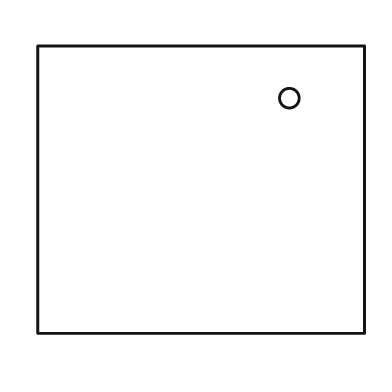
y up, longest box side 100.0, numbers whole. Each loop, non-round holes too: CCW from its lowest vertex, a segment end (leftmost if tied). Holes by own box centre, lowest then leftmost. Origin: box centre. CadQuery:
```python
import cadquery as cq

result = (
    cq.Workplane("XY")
    .moveTo(-50.0, -44.0)
    .lineTo(50.0, -44.0)
    .lineTo(50.0, 44.0)
    .lineTo(-50.0, 44.0)
    .close()
    .moveTo(27.0, 28.0)
    .circle(3.0)
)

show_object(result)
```